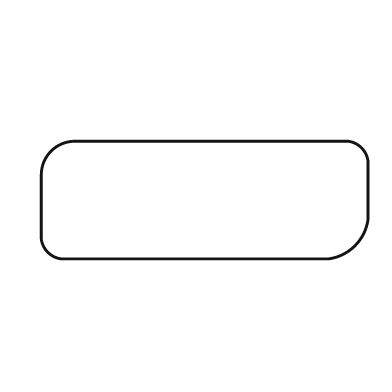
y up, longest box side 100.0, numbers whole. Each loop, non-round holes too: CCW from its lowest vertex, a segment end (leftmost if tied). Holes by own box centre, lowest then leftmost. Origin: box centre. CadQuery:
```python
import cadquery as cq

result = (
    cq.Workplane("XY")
    .moveTo(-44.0, -18.0)
    .lineTo(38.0, -18.0)
    .threePointArc((46.0, -14.0), (50.0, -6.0))
    .lineTo(50.0, 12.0)
    .threePointArc((48.0, 16.0), (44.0, 18.0))
    .lineTo(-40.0, 18.0)
    .threePointArc((-47.0, 15.0), (-50.0, 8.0))
    .lineTo(-50.0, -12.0)
    .threePointArc((-48.0, -16.0), (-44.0, -18.0))
    .close()
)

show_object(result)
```